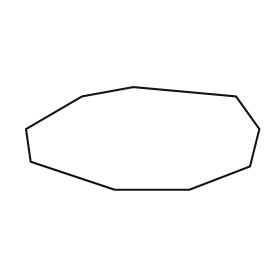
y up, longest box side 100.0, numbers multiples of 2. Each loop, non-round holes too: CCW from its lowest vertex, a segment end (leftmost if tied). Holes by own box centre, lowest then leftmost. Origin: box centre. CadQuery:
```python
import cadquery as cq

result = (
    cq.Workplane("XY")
    .moveTo(-12.0, -22.0)
    .lineTo(20.0, -22.0)
    .lineTo(46.0, -12.0)
    .lineTo(50.0, 4.0)
    .lineTo(40.0, 18.0)
    .lineTo(-4.0, 22.0)
    .lineTo(-26.0, 18.0)
    .lineTo(-50.0, 4.0)
    .lineTo(-48.0, -10.0)
    .close()
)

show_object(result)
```